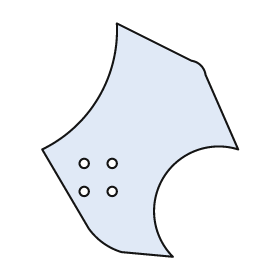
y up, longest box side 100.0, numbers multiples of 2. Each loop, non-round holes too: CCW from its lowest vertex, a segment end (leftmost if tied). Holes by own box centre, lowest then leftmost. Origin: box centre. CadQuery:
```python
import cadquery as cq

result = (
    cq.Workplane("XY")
    .moveTo(14.0, -50.0)
    .threePointArc((10.0, -16.0), (42.0, -4.0))
    .lineTo(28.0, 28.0)
    .threePointArc((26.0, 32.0), (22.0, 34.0))
    .lineTo(-10.0, 50.0)
    .threePointArc((-18.0, 18.0), (-42.0, -4.0))
    .lineTo(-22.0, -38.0)
    .threePointArc((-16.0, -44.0), (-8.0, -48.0))
    .close()
    .moveTo(-24.0, -22.0)
    .circle(2.0)
    .moveTo(-12.0, -22.0)
    .circle(2.0)
    .moveTo(-24.0, -10.0)
    .circle(2.0)
    .moveTo(-12.0, -10.0)
    .circle(2.0)
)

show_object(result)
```